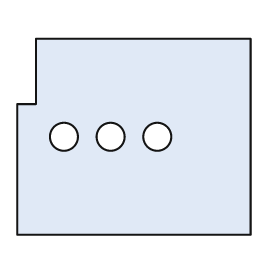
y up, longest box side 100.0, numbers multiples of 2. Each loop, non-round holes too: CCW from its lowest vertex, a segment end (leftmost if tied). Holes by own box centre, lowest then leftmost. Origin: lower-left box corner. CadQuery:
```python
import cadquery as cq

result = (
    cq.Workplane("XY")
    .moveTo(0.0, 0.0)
    .lineTo(100.0, 0.0)
    .lineTo(100.0, 84.0)
    .lineTo(8.0, 84.0)
    .lineTo(8.0, 56.0)
    .lineTo(0.0, 56.0)
    .close()
    .moveTo(20.0, 42.0)
    .circle(6.0)
    .moveTo(40.0, 42.0)
    .circle(6.0)
    .moveTo(60.0, 42.0)
    .circle(6.0)
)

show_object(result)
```